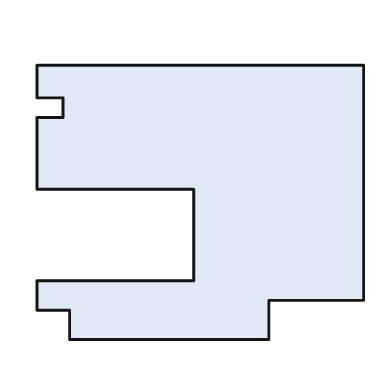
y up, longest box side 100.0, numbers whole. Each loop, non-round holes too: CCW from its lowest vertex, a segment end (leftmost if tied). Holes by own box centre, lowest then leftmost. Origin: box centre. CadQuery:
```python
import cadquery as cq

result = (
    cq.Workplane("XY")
    .moveTo(-40.0, -42.0)
    .lineTo(21.0, -42.0)
    .lineTo(21.0, -30.0)
    .lineTo(50.0, -30.0)
    .lineTo(50.0, 42.0)
    .lineTo(-50.0, 42.0)
    .lineTo(-50.0, 32.0)
    .lineTo(-42.0, 32.0)
    .lineTo(-42.0, 26.0)
    .lineTo(-50.0, 26.0)
    .lineTo(-50.0, 4.0)
    .lineTo(-2.0, 4.0)
    .lineTo(-2.0, -24.0)
    .lineTo(-50.0, -24.0)
    .lineTo(-50.0, -33.0)
    .lineTo(-40.0, -33.0)
    .close()
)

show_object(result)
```